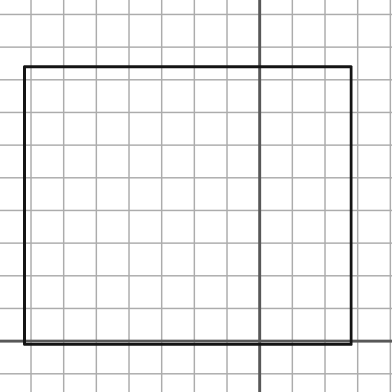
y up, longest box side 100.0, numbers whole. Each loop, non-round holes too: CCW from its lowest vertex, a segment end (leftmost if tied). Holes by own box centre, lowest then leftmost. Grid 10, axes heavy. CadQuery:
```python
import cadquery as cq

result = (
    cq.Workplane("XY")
    .moveTo(-72.0, -1.0)
    .lineTo(28.0, -1.0)
    .lineTo(28.0, 84.0)
    .lineTo(-72.0, 84.0)
    .close()
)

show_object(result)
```